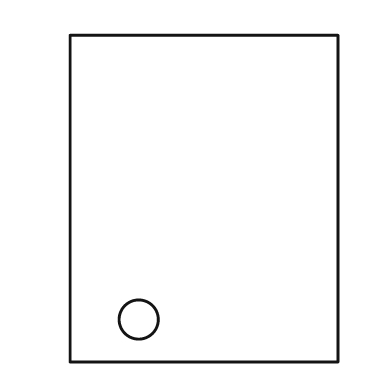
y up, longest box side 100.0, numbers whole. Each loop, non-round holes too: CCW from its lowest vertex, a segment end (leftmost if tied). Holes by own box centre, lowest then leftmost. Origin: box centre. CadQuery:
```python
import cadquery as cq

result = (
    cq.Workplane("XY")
    .moveTo(-41.0, -50.0)
    .lineTo(41.0, -50.0)
    .lineTo(41.0, 50.0)
    .lineTo(-41.0, 50.0)
    .close()
    .moveTo(-20.0, -37.0)
    .circle(6.0)
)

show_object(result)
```